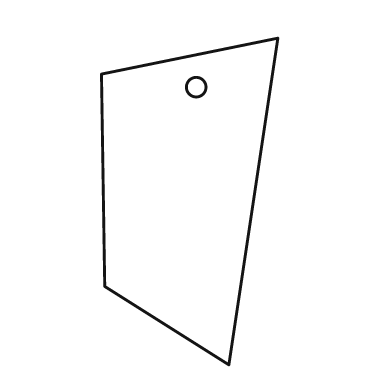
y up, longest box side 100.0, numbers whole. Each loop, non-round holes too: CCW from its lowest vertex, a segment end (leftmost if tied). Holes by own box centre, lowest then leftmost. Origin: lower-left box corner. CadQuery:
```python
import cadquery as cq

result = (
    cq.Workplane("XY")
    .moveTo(39.0, 0.0)
    .lineTo(54.0, 100.0)
    .lineTo(0.0, 89.0)
    .lineTo(1.0, 24.0)
    .close()
    .moveTo(29.0, 85.0)
    .circle(3.0)
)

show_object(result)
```